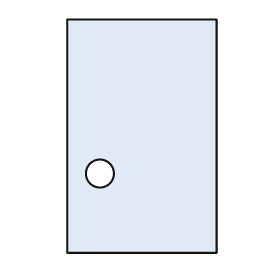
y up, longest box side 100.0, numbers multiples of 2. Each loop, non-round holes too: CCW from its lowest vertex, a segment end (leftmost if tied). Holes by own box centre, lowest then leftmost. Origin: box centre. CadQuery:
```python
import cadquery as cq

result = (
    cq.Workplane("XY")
    .moveTo(-32.0, -50.0)
    .lineTo(32.0, -50.0)
    .lineTo(32.0, 50.0)
    .lineTo(-32.0, 50.0)
    .close()
    .moveTo(-18.0, -16.0)
    .circle(6.0)
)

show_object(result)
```